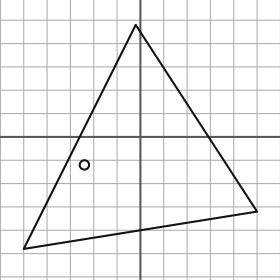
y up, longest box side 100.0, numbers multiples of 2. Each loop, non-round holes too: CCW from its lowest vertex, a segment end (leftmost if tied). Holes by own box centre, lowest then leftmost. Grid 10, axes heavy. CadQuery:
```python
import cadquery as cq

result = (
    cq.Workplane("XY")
    .moveTo(-50.0, -48.0)
    .lineTo(50.0, -32.0)
    .lineTo(-2.0, 48.0)
    .close()
    .moveTo(-24.0, -12.0)
    .circle(2.0)
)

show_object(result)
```